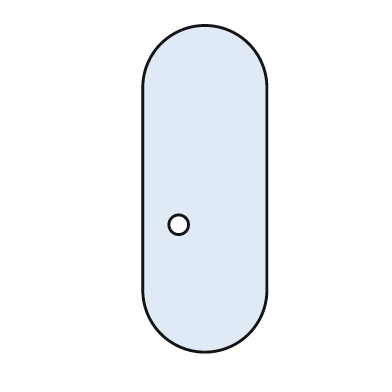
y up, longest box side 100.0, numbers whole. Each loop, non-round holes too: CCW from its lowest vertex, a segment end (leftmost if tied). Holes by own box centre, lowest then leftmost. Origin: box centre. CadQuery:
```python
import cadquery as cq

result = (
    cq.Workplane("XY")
    .moveTo(-19.0, -31.0)
    .threePointArc((0.0, -50.0), (19.0, -31.0))
    .lineTo(19.0, 31.0)
    .threePointArc((0.0, 50.0), (-19.0, 31.0))
    .close()
    .moveTo(-8.0, -11.0)
    .circle(3.0)
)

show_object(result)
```